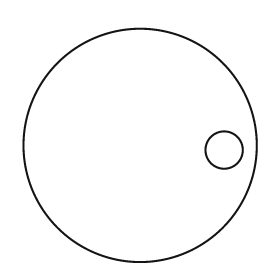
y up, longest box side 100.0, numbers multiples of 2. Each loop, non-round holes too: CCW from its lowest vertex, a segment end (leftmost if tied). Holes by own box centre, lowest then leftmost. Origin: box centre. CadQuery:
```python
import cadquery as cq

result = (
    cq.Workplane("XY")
    .moveTo(0.0, 0.0)
    .circle(50.0)
    .moveTo(36.0, -2.0)
    .circle(8.0)
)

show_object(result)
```